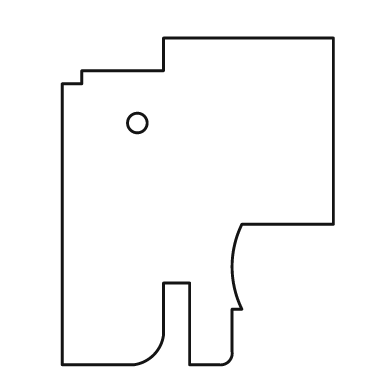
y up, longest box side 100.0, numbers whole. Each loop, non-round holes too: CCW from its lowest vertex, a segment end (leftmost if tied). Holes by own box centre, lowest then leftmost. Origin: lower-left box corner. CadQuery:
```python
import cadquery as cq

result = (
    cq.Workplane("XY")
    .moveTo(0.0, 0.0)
    .lineTo(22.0, 0.0)
    .threePointArc((28.0, 3.0), (31.0, 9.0))
    .lineTo(31.0, 25.0)
    .lineTo(39.0, 25.0)
    .lineTo(39.0, 0.0)
    .lineTo(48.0, 0.0)
    .threePointArc((51.0, 1.0), (52.0, 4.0))
    .lineTo(52.0, 17.0)
    .lineTo(55.0, 17.0)
    .threePointArc((52.0, 30.0), (55.0, 43.0))
    .lineTo(83.0, 43.0)
    .lineTo(83.0, 100.0)
    .lineTo(31.0, 100.0)
    .lineTo(31.0, 90.0)
    .lineTo(6.0, 90.0)
    .lineTo(6.0, 86.0)
    .lineTo(0.0, 86.0)
    .close()
    .moveTo(23.0, 74.0)
    .circle(3.0)
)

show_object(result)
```